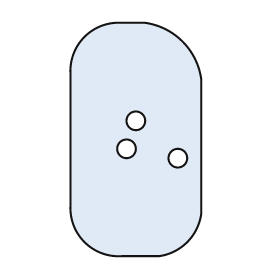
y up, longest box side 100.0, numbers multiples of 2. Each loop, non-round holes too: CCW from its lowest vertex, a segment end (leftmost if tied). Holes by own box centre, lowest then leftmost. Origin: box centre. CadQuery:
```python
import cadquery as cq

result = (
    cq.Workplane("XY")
    .moveTo(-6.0, -50.0)
    .lineTo(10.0, -50.0)
    .threePointArc((22.0, -44.0), (28.0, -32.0))
    .lineTo(28.0, 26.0)
    .threePointArc((20.0, 42.0), (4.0, 50.0))
    .lineTo(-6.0, 50.0)
    .threePointArc((-22.0, 44.0), (-28.0, 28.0))
    .lineTo(-28.0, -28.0)
    .threePointArc((-22.0, -44.0), (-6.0, -50.0))
    .close()
    .moveTo(18.0, -8.0)
    .circle(4.0)
    .moveTo(-4.0, -4.0)
    .circle(4.0)
    .moveTo(0.0, 8.0)
    .circle(4.0)
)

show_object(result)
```